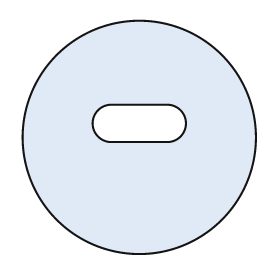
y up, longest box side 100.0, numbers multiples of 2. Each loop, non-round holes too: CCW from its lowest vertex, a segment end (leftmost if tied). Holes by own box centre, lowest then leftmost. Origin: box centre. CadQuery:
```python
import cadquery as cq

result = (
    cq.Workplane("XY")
    .moveTo(0.0, 0.0)
    .circle(50.0)
    .moveTo(-12.0, -2.0)
    .lineTo(12.0, -2.0)
    .threePointArc((20.0, 6.0), (12.0, 14.0))
    .lineTo(-12.0, 14.0)
    .threePointArc((-20.0, 6.0), (-12.0, -2.0))
    .close()
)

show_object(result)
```